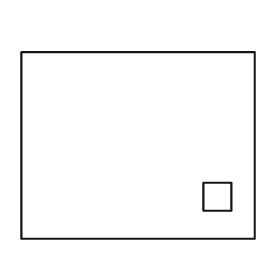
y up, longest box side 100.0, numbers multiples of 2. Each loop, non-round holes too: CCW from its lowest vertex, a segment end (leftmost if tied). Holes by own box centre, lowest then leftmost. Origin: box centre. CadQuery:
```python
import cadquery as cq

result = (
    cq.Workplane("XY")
    .moveTo(-50.0, -40.0)
    .lineTo(50.0, -40.0)
    .lineTo(50.0, 40.0)
    .lineTo(-50.0, 40.0)
    .close()
    .moveTo(28.0, -28.0)
    .lineTo(40.0, -28.0)
    .lineTo(40.0, -16.0)
    .lineTo(28.0, -16.0)
    .close()
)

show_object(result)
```